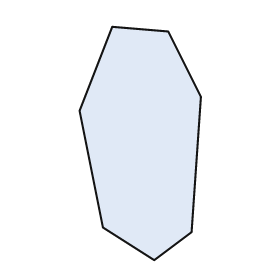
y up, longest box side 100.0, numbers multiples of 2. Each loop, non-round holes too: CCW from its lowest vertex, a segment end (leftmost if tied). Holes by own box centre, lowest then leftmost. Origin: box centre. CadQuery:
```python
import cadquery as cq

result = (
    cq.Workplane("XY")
    .moveTo(6.0, -50.0)
    .lineTo(22.0, -38.0)
    .lineTo(26.0, 20.0)
    .lineTo(12.0, 48.0)
    .lineTo(-12.0, 50.0)
    .lineTo(-26.0, 14.0)
    .lineTo(-16.0, -36.0)
    .close()
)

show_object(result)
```